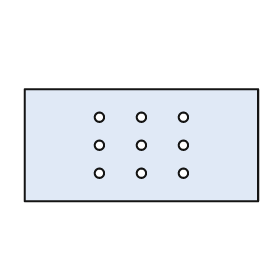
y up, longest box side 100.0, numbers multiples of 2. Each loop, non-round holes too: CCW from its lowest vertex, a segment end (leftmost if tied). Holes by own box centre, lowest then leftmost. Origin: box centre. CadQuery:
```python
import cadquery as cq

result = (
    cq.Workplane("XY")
    .moveTo(-50.0, -24.0)
    .lineTo(50.0, -24.0)
    .lineTo(50.0, 24.0)
    .lineTo(-50.0, 24.0)
    .close()
    .moveTo(-18.0, -12.0)
    .circle(2.0)
    .moveTo(0.0, -12.0)
    .circle(2.0)
    .moveTo(18.0, -12.0)
    .circle(2.0)
    .moveTo(-18.0, 0.0)
    .circle(2.0)
    .moveTo(0.0, 0.0)
    .circle(2.0)
    .moveTo(18.0, 0.0)
    .circle(2.0)
    .moveTo(-18.0, 12.0)
    .circle(2.0)
    .moveTo(0.0, 12.0)
    .circle(2.0)
    .moveTo(18.0, 12.0)
    .circle(2.0)
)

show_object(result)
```